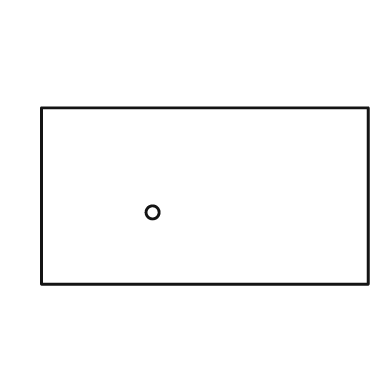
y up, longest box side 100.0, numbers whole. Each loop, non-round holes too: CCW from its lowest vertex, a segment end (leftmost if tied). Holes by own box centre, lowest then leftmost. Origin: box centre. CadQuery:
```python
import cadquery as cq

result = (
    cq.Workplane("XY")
    .moveTo(-50.0, -27.0)
    .lineTo(50.0, -27.0)
    .lineTo(50.0, 27.0)
    .lineTo(-50.0, 27.0)
    .close()
    .moveTo(-16.0, -5.0)
    .circle(2.0)
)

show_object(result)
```